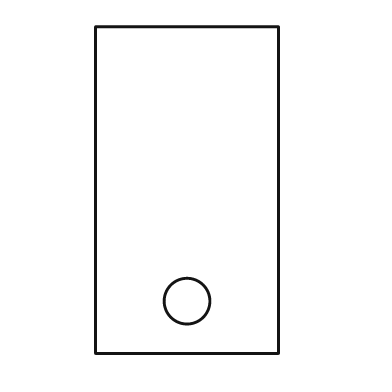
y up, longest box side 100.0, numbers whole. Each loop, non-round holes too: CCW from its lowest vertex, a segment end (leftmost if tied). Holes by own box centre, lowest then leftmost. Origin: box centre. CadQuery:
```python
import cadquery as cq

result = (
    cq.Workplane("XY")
    .moveTo(-28.0, -50.0)
    .lineTo(28.0, -50.0)
    .lineTo(28.0, 50.0)
    .lineTo(-28.0, 50.0)
    .close()
    .moveTo(0.0, -34.0)
    .circle(7.0)
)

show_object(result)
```